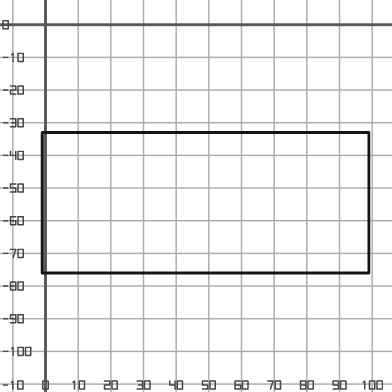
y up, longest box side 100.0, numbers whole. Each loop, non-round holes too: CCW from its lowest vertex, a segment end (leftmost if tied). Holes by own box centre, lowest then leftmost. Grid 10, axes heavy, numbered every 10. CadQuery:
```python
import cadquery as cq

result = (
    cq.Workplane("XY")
    .moveTo(-1.0, -76.0)
    .lineTo(99.0, -76.0)
    .lineTo(99.0, -33.0)
    .lineTo(-1.0, -33.0)
    .close()
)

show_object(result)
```